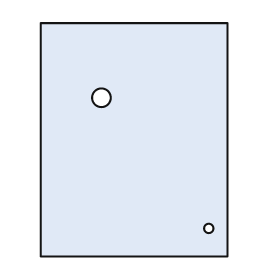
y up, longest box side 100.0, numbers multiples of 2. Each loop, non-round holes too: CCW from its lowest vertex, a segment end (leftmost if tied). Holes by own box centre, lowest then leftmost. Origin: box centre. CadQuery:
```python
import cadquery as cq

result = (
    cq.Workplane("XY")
    .moveTo(-40.0, -50.0)
    .lineTo(40.0, -50.0)
    .lineTo(40.0, 50.0)
    .lineTo(-40.0, 50.0)
    .close()
    .moveTo(32.0, -38.0)
    .circle(2.0)
    .moveTo(-14.0, 18.0)
    .circle(4.0)
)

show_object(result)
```